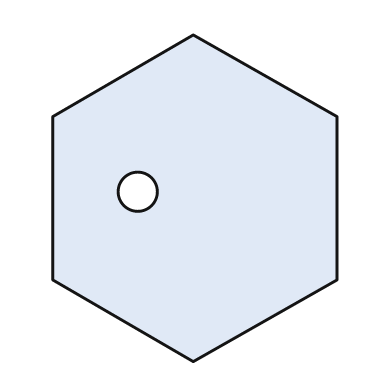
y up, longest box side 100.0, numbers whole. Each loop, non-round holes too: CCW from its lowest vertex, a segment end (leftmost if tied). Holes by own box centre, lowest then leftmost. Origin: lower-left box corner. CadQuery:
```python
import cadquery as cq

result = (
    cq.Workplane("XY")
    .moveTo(43.0, 0.0)
    .lineTo(87.0, 25.0)
    .lineTo(87.0, 75.0)
    .lineTo(43.0, 100.0)
    .lineTo(0.0, 75.0)
    .lineTo(0.0, 25.0)
    .close()
    .moveTo(26.0, 52.0)
    .circle(6.0)
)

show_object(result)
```